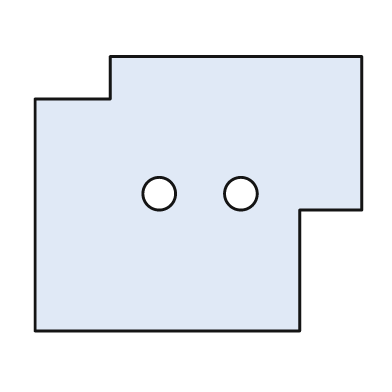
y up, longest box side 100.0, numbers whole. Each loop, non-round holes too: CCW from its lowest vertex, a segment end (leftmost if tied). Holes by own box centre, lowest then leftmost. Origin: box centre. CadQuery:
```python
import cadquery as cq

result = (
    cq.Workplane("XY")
    .moveTo(-50.0, -42.0)
    .lineTo(31.0, -42.0)
    .lineTo(31.0, -5.0)
    .lineTo(50.0, -5.0)
    .lineTo(50.0, 42.0)
    .lineTo(-27.0, 42.0)
    .lineTo(-27.0, 29.0)
    .lineTo(-50.0, 29.0)
    .close()
    .moveTo(-12.0, 0.0)
    .circle(5.0)
    .moveTo(13.0, 0.0)
    .circle(5.0)
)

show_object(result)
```